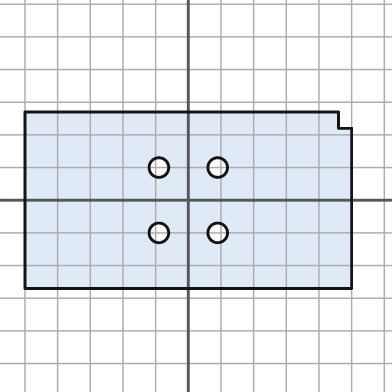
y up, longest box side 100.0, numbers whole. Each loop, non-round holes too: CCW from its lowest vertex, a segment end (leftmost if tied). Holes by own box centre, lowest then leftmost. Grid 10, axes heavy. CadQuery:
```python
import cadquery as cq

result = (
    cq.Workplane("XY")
    .moveTo(-50.0, -27.0)
    .lineTo(50.0, -27.0)
    .lineTo(50.0, 22.0)
    .lineTo(46.0, 22.0)
    .lineTo(46.0, 27.0)
    .lineTo(-50.0, 27.0)
    .close()
    .moveTo(-9.0, -10.0)
    .circle(3.0)
    .moveTo(9.0, -10.0)
    .circle(3.0)
    .moveTo(-9.0, 10.0)
    .circle(3.0)
    .moveTo(9.0, 10.0)
    .circle(3.0)
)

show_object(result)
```